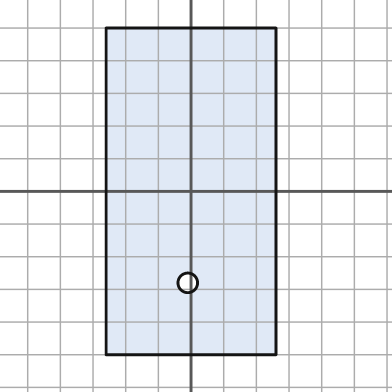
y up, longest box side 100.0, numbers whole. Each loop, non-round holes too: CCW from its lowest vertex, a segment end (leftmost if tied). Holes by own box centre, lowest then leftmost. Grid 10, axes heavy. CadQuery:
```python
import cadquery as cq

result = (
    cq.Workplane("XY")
    .moveTo(-26.0, -50.0)
    .lineTo(26.0, -50.0)
    .lineTo(26.0, 50.0)
    .lineTo(-26.0, 50.0)
    .close()
    .moveTo(-1.0, -28.0)
    .circle(3.0)
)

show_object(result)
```